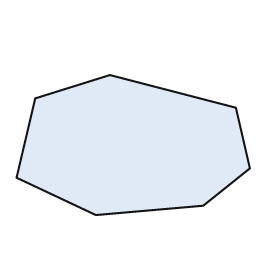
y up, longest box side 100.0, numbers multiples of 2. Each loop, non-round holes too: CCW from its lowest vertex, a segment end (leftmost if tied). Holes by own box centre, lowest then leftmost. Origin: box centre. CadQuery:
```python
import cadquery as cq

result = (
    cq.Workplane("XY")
    .moveTo(-16.0, -30.0)
    .lineTo(30.0, -26.0)
    .lineTo(50.0, -10.0)
    .lineTo(44.0, 16.0)
    .lineTo(-10.0, 30.0)
    .lineTo(-42.0, 20.0)
    .lineTo(-50.0, -14.0)
    .close()
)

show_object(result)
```